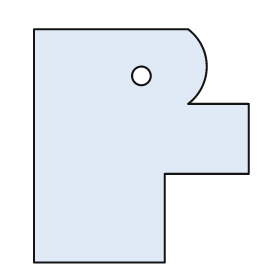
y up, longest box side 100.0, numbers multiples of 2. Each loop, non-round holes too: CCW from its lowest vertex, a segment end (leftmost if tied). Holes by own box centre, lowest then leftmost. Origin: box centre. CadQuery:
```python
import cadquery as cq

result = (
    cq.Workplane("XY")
    .moveTo(-46.0, -50.0)
    .lineTo(10.0, -50.0)
    .lineTo(10.0, -12.0)
    .lineTo(46.0, -12.0)
    .lineTo(46.0, 18.0)
    .lineTo(20.0, 18.0)
    .threePointArc((28.0, 34.0), (20.0, 50.0))
    .lineTo(-46.0, 50.0)
    .close()
    .moveTo(0.0, 30.0)
    .circle(4.0)
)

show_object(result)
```